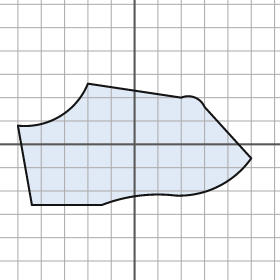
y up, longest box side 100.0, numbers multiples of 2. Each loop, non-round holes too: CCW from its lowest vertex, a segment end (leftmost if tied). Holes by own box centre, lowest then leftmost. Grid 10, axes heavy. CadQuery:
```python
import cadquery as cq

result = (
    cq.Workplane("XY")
    .moveTo(-44.0, -26.0)
    .lineTo(-14.0, -26.0)
    .threePointArc((2.0, -22.0), (18.0, -22.0))
    .threePointArc((36.0, -18.0), (50.0, -6.0))
    .lineTo(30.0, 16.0)
    .threePointArc((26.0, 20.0), (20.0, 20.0))
    .lineTo(-20.0, 26.0)
    .threePointArc((-32.0, 12.0), (-50.0, 8.0))
    .close()
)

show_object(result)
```